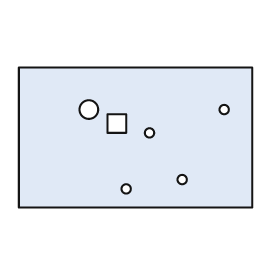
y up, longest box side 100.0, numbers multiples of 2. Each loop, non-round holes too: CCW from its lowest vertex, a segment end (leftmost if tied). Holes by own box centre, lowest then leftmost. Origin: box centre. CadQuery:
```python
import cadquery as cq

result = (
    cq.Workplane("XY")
    .moveTo(-50.0, -30.0)
    .lineTo(50.0, -30.0)
    .lineTo(50.0, 30.0)
    .lineTo(-50.0, 30.0)
    .close()
    .moveTo(-4.0, -22.0)
    .circle(2.0)
    .moveTo(20.0, -18.0)
    .circle(2.0)
    .moveTo(6.0, 2.0)
    .circle(2.0)
    .moveTo(-12.0, 2.0)
    .lineTo(-4.0, 2.0)
    .lineTo(-4.0, 10.0)
    .lineTo(-12.0, 10.0)
    .close()
    .moveTo(-20.0, 12.0)
    .circle(4.0)
    .moveTo(38.0, 12.0)
    .circle(2.0)
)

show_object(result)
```